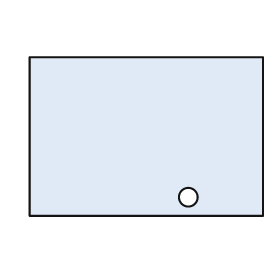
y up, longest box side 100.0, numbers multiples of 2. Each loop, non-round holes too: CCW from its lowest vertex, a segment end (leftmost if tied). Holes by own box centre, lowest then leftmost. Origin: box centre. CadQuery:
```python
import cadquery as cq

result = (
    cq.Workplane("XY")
    .moveTo(-50.0, -34.0)
    .lineTo(50.0, -34.0)
    .lineTo(50.0, 34.0)
    .lineTo(-50.0, 34.0)
    .close()
    .moveTo(18.0, -26.0)
    .circle(4.0)
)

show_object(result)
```